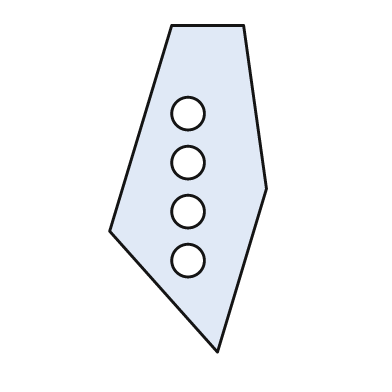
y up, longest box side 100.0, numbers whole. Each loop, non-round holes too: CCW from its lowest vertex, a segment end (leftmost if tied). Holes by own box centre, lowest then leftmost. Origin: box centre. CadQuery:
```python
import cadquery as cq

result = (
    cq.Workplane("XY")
    .moveTo(9.0, -50.0)
    .lineTo(24.0, 0.0)
    .lineTo(17.0, 50.0)
    .lineTo(-5.0, 50.0)
    .lineTo(-24.0, -13.0)
    .close()
    .moveTo(0.0, -22.0)
    .circle(5.0)
    .moveTo(0.0, -7.0)
    .circle(5.0)
    .moveTo(0.0, 8.0)
    .circle(5.0)
    .moveTo(0.0, 23.0)
    .circle(5.0)
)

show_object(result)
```